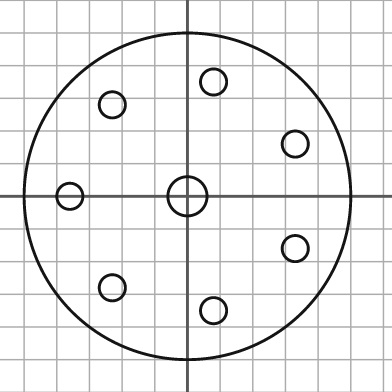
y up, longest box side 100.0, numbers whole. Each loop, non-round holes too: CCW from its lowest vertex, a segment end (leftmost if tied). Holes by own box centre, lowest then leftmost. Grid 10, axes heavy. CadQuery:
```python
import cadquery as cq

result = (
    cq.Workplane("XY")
    .moveTo(0.0, 0.0)
    .circle(50.0)
    .moveTo(8.0, -35.0)
    .circle(4.0)
    .moveTo(-23.0, -28.0)
    .circle(4.0)
    .moveTo(33.0, -16.0)
    .circle(4.0)
    .moveTo(-36.0, 0.0)
    .circle(4.0)
    .moveTo(0.0, 0.0)
    .circle(6.0)
    .moveTo(33.0, 16.0)
    .circle(4.0)
    .moveTo(-23.0, 28.0)
    .circle(4.0)
    .moveTo(8.0, 35.0)
    .circle(4.0)
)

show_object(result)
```